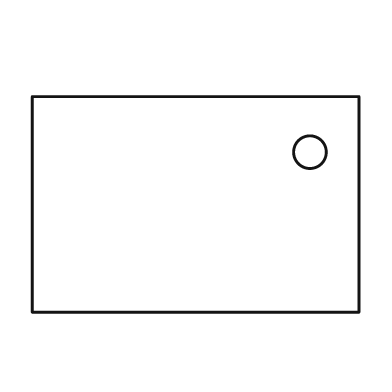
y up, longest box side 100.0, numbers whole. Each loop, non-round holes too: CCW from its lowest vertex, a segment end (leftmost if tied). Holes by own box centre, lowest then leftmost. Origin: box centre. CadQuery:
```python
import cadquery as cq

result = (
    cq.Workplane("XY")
    .moveTo(-50.0, -33.0)
    .lineTo(50.0, -33.0)
    .lineTo(50.0, 33.0)
    .lineTo(-50.0, 33.0)
    .close()
    .moveTo(35.0, 16.0)
    .circle(5.0)
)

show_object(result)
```